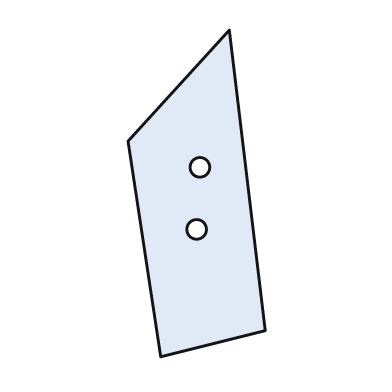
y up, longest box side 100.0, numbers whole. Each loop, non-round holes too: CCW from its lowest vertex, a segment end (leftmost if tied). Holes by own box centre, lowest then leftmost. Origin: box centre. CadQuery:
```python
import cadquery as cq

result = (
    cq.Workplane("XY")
    .moveTo(-11.0, -50.0)
    .lineTo(21.0, -42.0)
    .lineTo(10.0, 50.0)
    .lineTo(-21.0, 16.0)
    .close()
    .moveTo(0.0, -11.0)
    .circle(3.0)
    .moveTo(1.0, 8.0)
    .circle(3.0)
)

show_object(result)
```